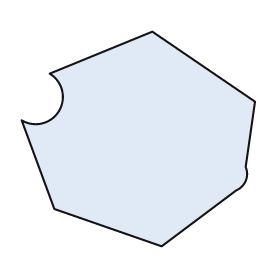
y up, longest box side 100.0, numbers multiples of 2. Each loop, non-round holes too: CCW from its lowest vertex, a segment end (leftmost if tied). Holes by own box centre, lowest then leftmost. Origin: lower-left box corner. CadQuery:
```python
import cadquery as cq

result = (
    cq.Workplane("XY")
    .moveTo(60.0, 0.0)
    .lineTo(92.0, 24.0)
    .threePointArc((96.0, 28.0), (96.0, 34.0))
    .lineTo(100.0, 62.0)
    .lineTo(56.0, 92.0)
    .lineTo(12.0, 74.0)
    .threePointArc((16.0, 58.0), (0.0, 54.0))
    .lineTo(14.0, 16.0)
    .close()
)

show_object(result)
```